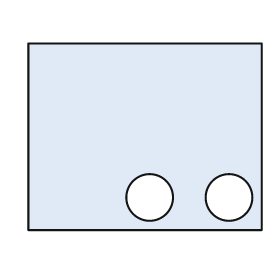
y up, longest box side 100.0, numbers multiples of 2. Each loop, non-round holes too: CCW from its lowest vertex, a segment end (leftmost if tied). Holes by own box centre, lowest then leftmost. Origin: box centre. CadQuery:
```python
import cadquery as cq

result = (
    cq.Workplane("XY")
    .moveTo(-50.0, -40.0)
    .lineTo(50.0, -40.0)
    .lineTo(50.0, 40.0)
    .lineTo(-50.0, 40.0)
    .close()
    .moveTo(2.0, -26.0)
    .circle(10.0)
    .moveTo(36.0, -26.0)
    .circle(10.0)
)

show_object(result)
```